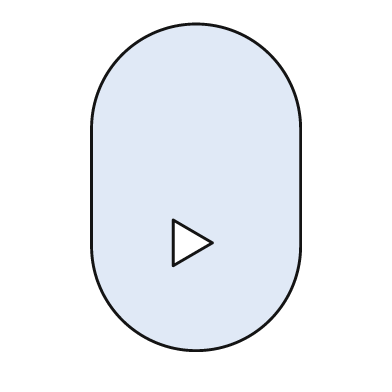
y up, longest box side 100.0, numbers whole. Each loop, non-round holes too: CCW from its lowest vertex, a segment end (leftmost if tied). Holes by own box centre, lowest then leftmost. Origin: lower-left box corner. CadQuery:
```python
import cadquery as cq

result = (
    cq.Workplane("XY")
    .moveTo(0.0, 32.0)
    .threePointArc((32.0, 0.0), (64.0, 32.0))
    .lineTo(64.0, 68.0)
    .threePointArc((32.0, 100.0), (0.0, 68.0))
    .close()
    .moveTo(25.0, 26.0)
    .lineTo(37.0, 33.0)
    .lineTo(25.0, 40.0)
    .close()
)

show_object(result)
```